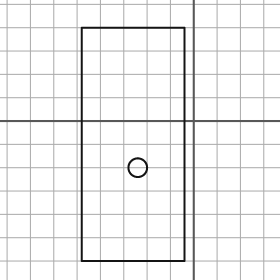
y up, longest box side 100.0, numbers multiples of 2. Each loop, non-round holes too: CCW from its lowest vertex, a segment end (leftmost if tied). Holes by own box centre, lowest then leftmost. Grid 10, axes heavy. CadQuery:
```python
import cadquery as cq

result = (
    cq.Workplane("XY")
    .moveTo(-48.0, -60.0)
    .lineTo(-4.0, -60.0)
    .lineTo(-4.0, 40.0)
    .lineTo(-48.0, 40.0)
    .close()
    .moveTo(-24.0, -20.0)
    .circle(4.0)
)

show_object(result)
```